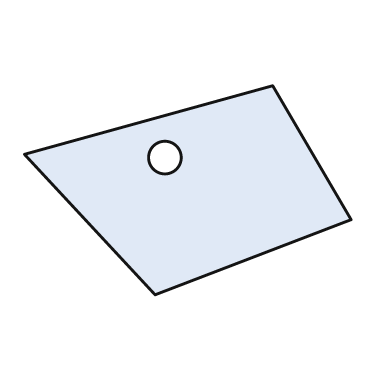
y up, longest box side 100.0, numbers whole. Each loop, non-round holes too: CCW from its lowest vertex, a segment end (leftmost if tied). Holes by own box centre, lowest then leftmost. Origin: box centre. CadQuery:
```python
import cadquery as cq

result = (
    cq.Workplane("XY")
    .moveTo(-10.0, -32.0)
    .lineTo(50.0, -9.0)
    .lineTo(26.0, 32.0)
    .lineTo(-50.0, 11.0)
    .close()
    .moveTo(-7.0, 10.0)
    .circle(5.0)
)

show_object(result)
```